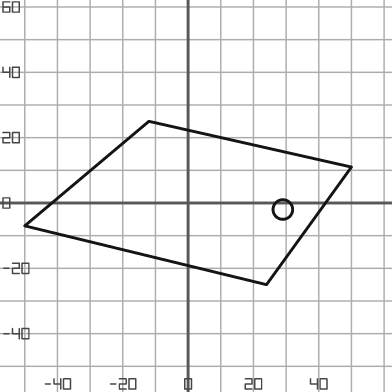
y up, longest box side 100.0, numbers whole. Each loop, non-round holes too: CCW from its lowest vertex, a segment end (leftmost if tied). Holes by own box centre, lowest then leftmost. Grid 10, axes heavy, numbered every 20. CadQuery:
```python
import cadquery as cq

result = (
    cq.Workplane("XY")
    .moveTo(24.0, -25.0)
    .lineTo(50.0, 11.0)
    .lineTo(-12.0, 25.0)
    .lineTo(-50.0, -7.0)
    .close()
    .moveTo(29.0, -2.0)
    .circle(3.0)
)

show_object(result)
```